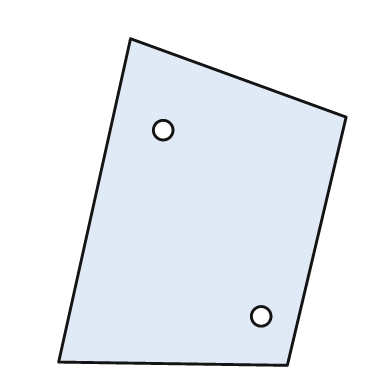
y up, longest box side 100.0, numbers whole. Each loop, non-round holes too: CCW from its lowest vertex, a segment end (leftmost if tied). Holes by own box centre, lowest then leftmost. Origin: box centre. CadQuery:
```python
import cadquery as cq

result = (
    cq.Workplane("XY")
    .moveTo(26.0, -50.0)
    .lineTo(44.0, 26.0)
    .lineTo(-22.0, 50.0)
    .lineTo(-44.0, -49.0)
    .close()
    .moveTo(18.0, -35.0)
    .circle(3.0)
    .moveTo(-12.0, 22.0)
    .circle(3.0)
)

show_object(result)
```